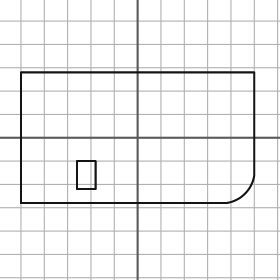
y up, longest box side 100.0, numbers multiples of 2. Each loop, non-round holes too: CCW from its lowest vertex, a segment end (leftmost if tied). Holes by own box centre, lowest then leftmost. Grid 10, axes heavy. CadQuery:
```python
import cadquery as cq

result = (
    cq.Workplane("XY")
    .moveTo(-50.0, -28.0)
    .lineTo(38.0, -28.0)
    .threePointArc((46.0, -24.0), (50.0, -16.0))
    .lineTo(50.0, 28.0)
    .lineTo(-50.0, 28.0)
    .close()
    .moveTo(-26.0, -22.0)
    .lineTo(-18.0, -22.0)
    .lineTo(-18.0, -10.0)
    .lineTo(-26.0, -10.0)
    .close()
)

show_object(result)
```